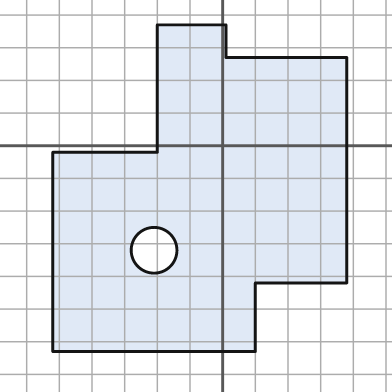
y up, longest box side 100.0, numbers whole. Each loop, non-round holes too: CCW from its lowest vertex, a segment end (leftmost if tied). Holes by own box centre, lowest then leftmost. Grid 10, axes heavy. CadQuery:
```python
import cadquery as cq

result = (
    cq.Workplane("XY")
    .moveTo(-52.0, -63.0)
    .lineTo(10.0, -63.0)
    .lineTo(10.0, -42.0)
    .lineTo(38.0, -42.0)
    .lineTo(38.0, 27.0)
    .lineTo(1.0, 27.0)
    .lineTo(1.0, 37.0)
    .lineTo(-20.0, 37.0)
    .lineTo(-20.0, -2.0)
    .lineTo(-52.0, -2.0)
    .close()
    .moveTo(-21.0, -32.0)
    .circle(7.0)
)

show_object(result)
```